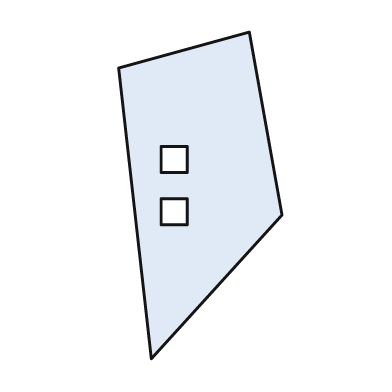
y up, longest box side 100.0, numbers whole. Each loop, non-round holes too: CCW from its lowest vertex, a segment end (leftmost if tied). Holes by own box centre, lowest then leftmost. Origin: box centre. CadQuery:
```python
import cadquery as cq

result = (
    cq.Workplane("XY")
    .moveTo(-15.0, -50.0)
    .lineTo(25.0, -6.0)
    .lineTo(15.0, 50.0)
    .lineTo(-25.0, 39.0)
    .close()
    .moveTo(-12.0, -9.0)
    .lineTo(-4.0, -9.0)
    .lineTo(-4.0, -1.0)
    .lineTo(-12.0, -1.0)
    .close()
    .moveTo(-12.0, 7.0)
    .lineTo(-4.0, 7.0)
    .lineTo(-4.0, 15.0)
    .lineTo(-12.0, 15.0)
    .close()
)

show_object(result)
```